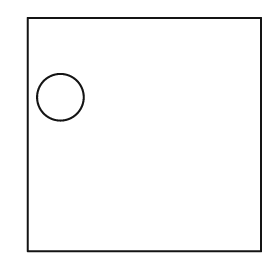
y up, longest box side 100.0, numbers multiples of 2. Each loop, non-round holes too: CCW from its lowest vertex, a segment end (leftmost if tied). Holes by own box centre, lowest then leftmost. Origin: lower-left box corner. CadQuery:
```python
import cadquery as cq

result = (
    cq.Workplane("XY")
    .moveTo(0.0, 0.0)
    .lineTo(100.0, 0.0)
    .lineTo(100.0, 100.0)
    .lineTo(0.0, 100.0)
    .close()
    .moveTo(14.0, 66.0)
    .circle(10.0)
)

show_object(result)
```